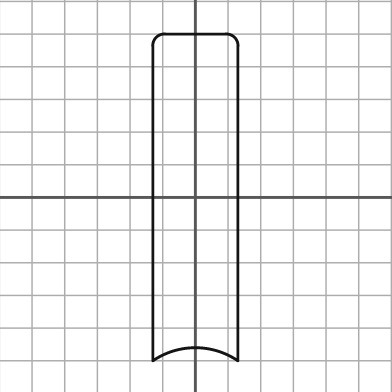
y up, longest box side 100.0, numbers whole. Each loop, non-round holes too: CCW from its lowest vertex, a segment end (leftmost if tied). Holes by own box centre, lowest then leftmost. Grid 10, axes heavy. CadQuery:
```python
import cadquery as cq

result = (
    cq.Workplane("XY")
    .moveTo(-13.0, -50.0)
    .threePointArc((0.0, -46.0), (13.0, -50.0))
    .lineTo(13.0, 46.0)
    .threePointArc((12.0, 49.0), (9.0, 50.0))
    .lineTo(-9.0, 50.0)
    .threePointArc((-12.0, 49.0), (-13.0, 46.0))
    .close()
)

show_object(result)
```